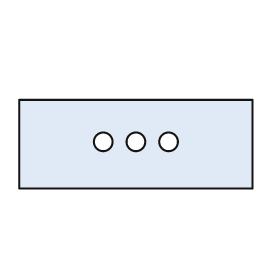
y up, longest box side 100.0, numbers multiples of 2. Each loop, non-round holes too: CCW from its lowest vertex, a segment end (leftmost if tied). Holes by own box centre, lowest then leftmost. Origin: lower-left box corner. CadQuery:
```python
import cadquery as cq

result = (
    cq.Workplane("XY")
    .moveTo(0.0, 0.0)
    .lineTo(100.0, 0.0)
    .lineTo(100.0, 38.0)
    .lineTo(0.0, 38.0)
    .close()
    .moveTo(36.0, 20.0)
    .circle(4.0)
    .moveTo(50.0, 20.0)
    .circle(4.0)
    .moveTo(64.0, 20.0)
    .circle(4.0)
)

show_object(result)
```